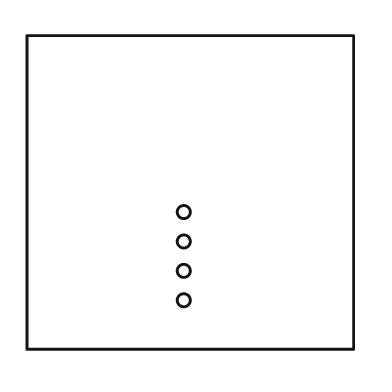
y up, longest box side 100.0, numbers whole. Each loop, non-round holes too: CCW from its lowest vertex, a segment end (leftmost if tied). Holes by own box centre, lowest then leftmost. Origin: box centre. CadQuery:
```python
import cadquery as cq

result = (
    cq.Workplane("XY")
    .moveTo(-50.0, -48.0)
    .lineTo(50.0, -48.0)
    .lineTo(50.0, 48.0)
    .lineTo(-50.0, 48.0)
    .close()
    .moveTo(-2.0, -33.0)
    .circle(2.0)
    .moveTo(-2.0, -24.0)
    .circle(2.0)
    .moveTo(-2.0, -15.0)
    .circle(2.0)
    .moveTo(-2.0, -6.0)
    .circle(2.0)
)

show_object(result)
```